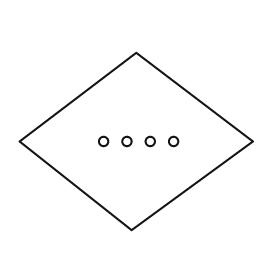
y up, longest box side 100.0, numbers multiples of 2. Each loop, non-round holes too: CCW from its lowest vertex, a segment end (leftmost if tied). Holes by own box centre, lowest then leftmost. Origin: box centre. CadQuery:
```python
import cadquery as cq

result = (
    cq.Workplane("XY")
    .moveTo(-2.0, -38.0)
    .lineTo(50.0, 0.0)
    .lineTo(0.0, 38.0)
    .lineTo(-50.0, 0.0)
    .close()
    .moveTo(-14.0, 0.0)
    .circle(2.0)
    .moveTo(-4.0, 0.0)
    .circle(2.0)
    .moveTo(6.0, 0.0)
    .circle(2.0)
    .moveTo(16.0, 0.0)
    .circle(2.0)
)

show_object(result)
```